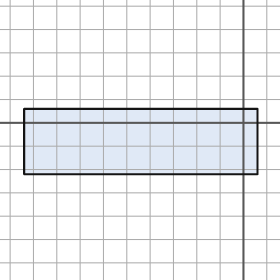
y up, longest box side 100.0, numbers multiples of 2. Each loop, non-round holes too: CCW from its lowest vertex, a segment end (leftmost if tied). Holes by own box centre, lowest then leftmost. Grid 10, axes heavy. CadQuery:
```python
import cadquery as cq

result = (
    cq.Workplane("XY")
    .moveTo(-94.0, -22.0)
    .lineTo(6.0, -22.0)
    .lineTo(6.0, 6.0)
    .lineTo(-94.0, 6.0)
    .close()
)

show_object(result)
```